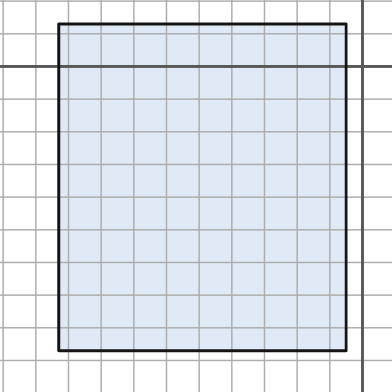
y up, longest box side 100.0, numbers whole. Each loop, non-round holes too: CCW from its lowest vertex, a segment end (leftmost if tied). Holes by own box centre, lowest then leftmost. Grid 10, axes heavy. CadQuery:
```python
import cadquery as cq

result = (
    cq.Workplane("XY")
    .moveTo(-93.0, -87.0)
    .lineTo(-5.0, -87.0)
    .lineTo(-5.0, 13.0)
    .lineTo(-93.0, 13.0)
    .close()
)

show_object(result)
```